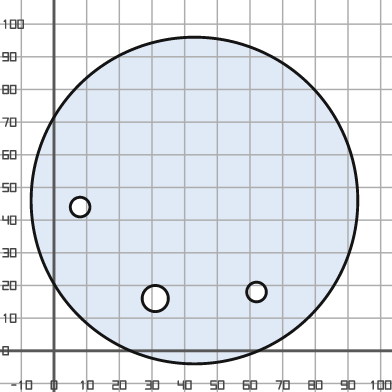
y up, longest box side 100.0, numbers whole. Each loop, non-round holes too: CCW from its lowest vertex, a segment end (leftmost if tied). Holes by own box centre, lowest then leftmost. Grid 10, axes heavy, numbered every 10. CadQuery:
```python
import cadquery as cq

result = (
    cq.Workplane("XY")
    .moveTo(43.0, 46.0)
    .circle(50.0)
    .moveTo(31.0, 16.0)
    .circle(4.0)
    .moveTo(62.0, 18.0)
    .circle(3.0)
    .moveTo(8.0, 44.0)
    .circle(3.0)
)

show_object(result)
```